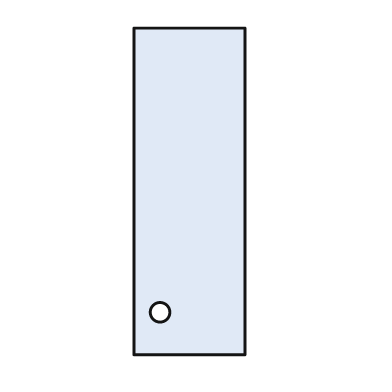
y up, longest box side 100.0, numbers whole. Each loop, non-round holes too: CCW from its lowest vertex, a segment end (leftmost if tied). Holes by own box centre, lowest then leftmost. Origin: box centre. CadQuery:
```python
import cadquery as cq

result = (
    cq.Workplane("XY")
    .moveTo(-17.0, -50.0)
    .lineTo(17.0, -50.0)
    .lineTo(17.0, 50.0)
    .lineTo(-17.0, 50.0)
    .close()
    .moveTo(-9.0, -37.0)
    .circle(3.0)
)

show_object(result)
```